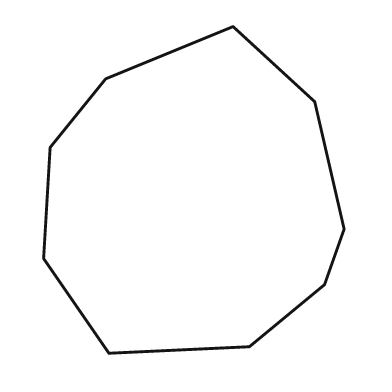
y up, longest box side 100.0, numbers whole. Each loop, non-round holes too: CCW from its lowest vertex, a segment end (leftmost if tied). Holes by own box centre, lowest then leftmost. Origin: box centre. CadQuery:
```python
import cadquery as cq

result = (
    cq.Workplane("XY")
    .moveTo(-26.0, -50.0)
    .lineTo(17.0, -48.0)
    .lineTo(40.0, -29.0)
    .lineTo(46.0, -12.0)
    .lineTo(37.0, 27.0)
    .lineTo(12.0, 50.0)
    .lineTo(-27.0, 34.0)
    .lineTo(-44.0, 13.0)
    .lineTo(-46.0, -21.0)
    .close()
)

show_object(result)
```